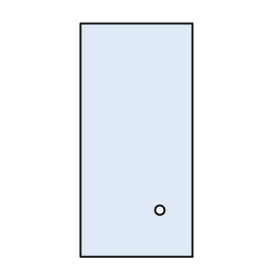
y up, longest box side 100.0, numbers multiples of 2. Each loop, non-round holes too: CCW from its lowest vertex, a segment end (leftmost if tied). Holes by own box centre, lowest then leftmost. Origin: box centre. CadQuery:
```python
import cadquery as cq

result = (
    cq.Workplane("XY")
    .moveTo(-24.0, -50.0)
    .lineTo(24.0, -50.0)
    .lineTo(24.0, 50.0)
    .lineTo(-24.0, 50.0)
    .close()
    .moveTo(10.0, -30.0)
    .circle(2.0)
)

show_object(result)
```